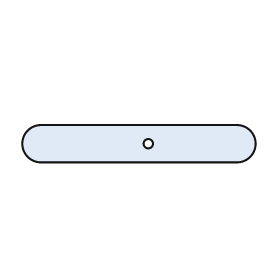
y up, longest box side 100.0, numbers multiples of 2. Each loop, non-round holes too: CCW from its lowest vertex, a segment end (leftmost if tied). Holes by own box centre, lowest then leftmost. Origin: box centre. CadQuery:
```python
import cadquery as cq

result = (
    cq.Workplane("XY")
    .moveTo(-42.0, -8.0)
    .lineTo(42.0, -8.0)
    .threePointArc((50.0, 0.0), (42.0, 8.0))
    .lineTo(-42.0, 8.0)
    .threePointArc((-50.0, 0.0), (-42.0, -8.0))
    .close()
    .moveTo(4.0, 0.0)
    .circle(2.0)
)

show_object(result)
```